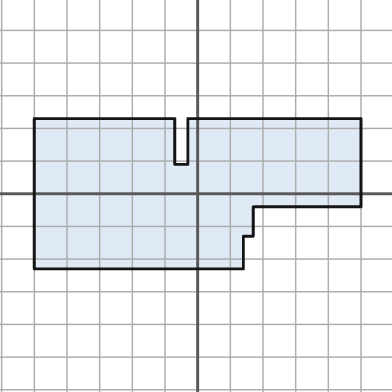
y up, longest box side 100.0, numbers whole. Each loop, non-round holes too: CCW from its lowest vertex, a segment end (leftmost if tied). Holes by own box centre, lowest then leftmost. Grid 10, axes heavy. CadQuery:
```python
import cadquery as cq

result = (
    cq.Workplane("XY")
    .moveTo(-50.0, -23.0)
    .lineTo(14.0, -23.0)
    .lineTo(14.0, -13.0)
    .lineTo(17.0, -13.0)
    .lineTo(17.0, -4.0)
    .lineTo(50.0, -4.0)
    .lineTo(50.0, 23.0)
    .lineTo(-3.0, 23.0)
    .lineTo(-3.0, 9.0)
    .lineTo(-7.0, 9.0)
    .lineTo(-7.0, 23.0)
    .lineTo(-50.0, 23.0)
    .close()
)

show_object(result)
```